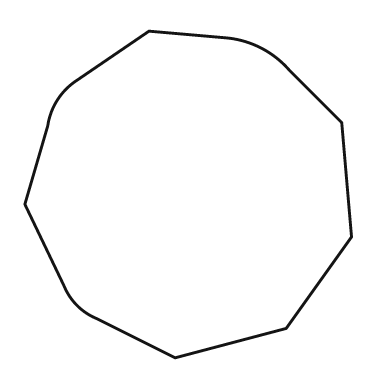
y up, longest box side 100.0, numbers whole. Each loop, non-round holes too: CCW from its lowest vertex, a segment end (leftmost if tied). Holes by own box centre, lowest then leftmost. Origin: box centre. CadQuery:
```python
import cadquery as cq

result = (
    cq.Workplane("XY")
    .moveTo(-4.0, -50.0)
    .lineTo(30.0, -41.0)
    .lineTo(50.0, -13.0)
    .lineTo(47.0, 22.0)
    .lineTo(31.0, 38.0)
    .threePointArc((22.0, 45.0), (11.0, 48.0))
    .lineTo(-12.0, 50.0)
    .lineTo(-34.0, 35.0)
    .threePointArc((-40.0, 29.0), (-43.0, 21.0))
    .lineTo(-50.0, -3.0)
    .lineTo(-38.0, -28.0)
    .threePointArc((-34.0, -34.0), (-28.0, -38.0))
    .close()
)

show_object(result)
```